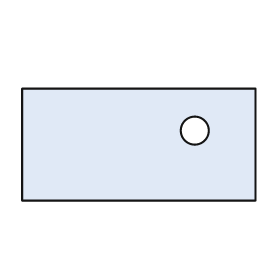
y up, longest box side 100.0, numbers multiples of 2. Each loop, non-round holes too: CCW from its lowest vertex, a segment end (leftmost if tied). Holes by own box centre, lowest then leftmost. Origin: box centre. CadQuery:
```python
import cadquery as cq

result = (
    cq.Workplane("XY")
    .moveTo(-50.0, -24.0)
    .lineTo(50.0, -24.0)
    .lineTo(50.0, 24.0)
    .lineTo(-50.0, 24.0)
    .close()
    .moveTo(24.0, 6.0)
    .circle(6.0)
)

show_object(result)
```